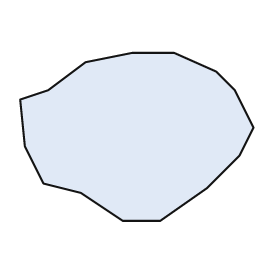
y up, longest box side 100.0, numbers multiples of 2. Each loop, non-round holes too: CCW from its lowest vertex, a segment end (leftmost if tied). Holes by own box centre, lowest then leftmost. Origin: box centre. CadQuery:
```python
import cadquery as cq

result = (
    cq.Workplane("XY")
    .moveTo(-6.0, -36.0)
    .lineTo(10.0, -36.0)
    .lineTo(30.0, -22.0)
    .lineTo(44.0, -8.0)
    .lineTo(50.0, 4.0)
    .lineTo(42.0, 20.0)
    .lineTo(34.0, 28.0)
    .lineTo(16.0, 36.0)
    .lineTo(-2.0, 36.0)
    .lineTo(-22.0, 32.0)
    .lineTo(-38.0, 20.0)
    .lineTo(-50.0, 16.0)
    .lineTo(-48.0, -4.0)
    .lineTo(-40.0, -20.0)
    .lineTo(-24.0, -24.0)
    .close()
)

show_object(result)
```